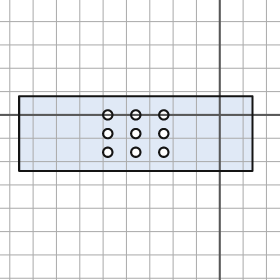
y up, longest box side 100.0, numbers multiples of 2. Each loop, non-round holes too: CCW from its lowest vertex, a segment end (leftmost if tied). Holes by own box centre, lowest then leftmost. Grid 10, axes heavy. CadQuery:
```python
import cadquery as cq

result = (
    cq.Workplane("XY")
    .moveTo(-86.0, -24.0)
    .lineTo(14.0, -24.0)
    .lineTo(14.0, 8.0)
    .lineTo(-86.0, 8.0)
    .close()
    .moveTo(-48.0, -16.0)
    .circle(2.0)
    .moveTo(-36.0, -16.0)
    .circle(2.0)
    .moveTo(-24.0, -16.0)
    .circle(2.0)
    .moveTo(-48.0, -8.0)
    .circle(2.0)
    .moveTo(-36.0, -8.0)
    .circle(2.0)
    .moveTo(-24.0, -8.0)
    .circle(2.0)
    .moveTo(-48.0, 0.0)
    .circle(2.0)
    .moveTo(-36.0, 0.0)
    .circle(2.0)
    .moveTo(-24.0, 0.0)
    .circle(2.0)
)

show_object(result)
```